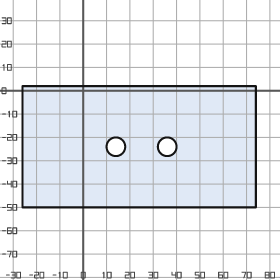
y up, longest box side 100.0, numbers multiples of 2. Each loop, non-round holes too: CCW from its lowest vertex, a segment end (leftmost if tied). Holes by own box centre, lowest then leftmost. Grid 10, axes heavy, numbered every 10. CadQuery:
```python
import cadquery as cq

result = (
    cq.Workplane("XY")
    .moveTo(-26.0, -50.0)
    .lineTo(74.0, -50.0)
    .lineTo(74.0, 2.0)
    .lineTo(-26.0, 2.0)
    .close()
    .moveTo(14.0, -24.0)
    .circle(4.0)
    .moveTo(36.0, -24.0)
    .circle(4.0)
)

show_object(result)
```